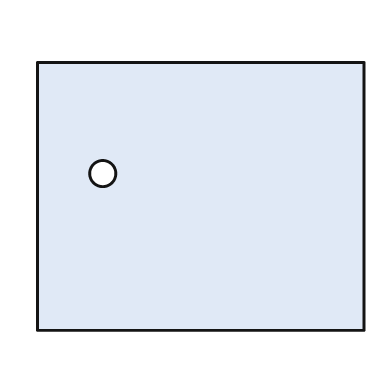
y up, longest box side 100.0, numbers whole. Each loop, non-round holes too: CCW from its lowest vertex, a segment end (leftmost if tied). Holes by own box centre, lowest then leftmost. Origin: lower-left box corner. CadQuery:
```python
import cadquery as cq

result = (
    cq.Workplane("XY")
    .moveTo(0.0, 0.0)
    .lineTo(100.0, 0.0)
    .lineTo(100.0, 82.0)
    .lineTo(0.0, 82.0)
    .close()
    .moveTo(20.0, 48.0)
    .circle(4.0)
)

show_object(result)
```